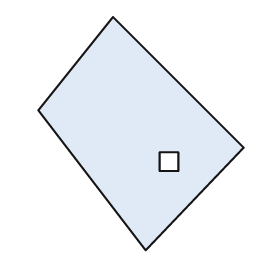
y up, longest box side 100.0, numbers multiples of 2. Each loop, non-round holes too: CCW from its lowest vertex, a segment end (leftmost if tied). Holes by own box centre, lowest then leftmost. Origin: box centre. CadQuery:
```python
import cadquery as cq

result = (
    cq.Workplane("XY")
    .moveTo(2.0, -50.0)
    .lineTo(44.0, -6.0)
    .lineTo(-12.0, 50.0)
    .lineTo(-44.0, 10.0)
    .close()
    .moveTo(8.0, -16.0)
    .lineTo(16.0, -16.0)
    .lineTo(16.0, -8.0)
    .lineTo(8.0, -8.0)
    .close()
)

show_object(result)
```